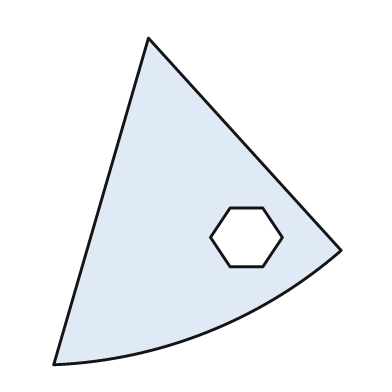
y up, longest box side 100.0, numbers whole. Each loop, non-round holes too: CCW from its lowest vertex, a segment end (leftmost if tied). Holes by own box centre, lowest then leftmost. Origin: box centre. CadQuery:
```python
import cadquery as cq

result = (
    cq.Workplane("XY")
    .moveTo(-44.0, -50.0)
    .threePointArc((3.0, -40.0), (44.0, -15.0))
    .lineTo(-15.0, 50.0)
    .close()
    .moveTo(10.0, -20.0)
    .lineTo(20.0, -20.0)
    .lineTo(26.0, -11.0)
    .lineTo(20.0, -2.0)
    .lineTo(10.0, -2.0)
    .lineTo(4.0, -11.0)
    .close()
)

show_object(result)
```